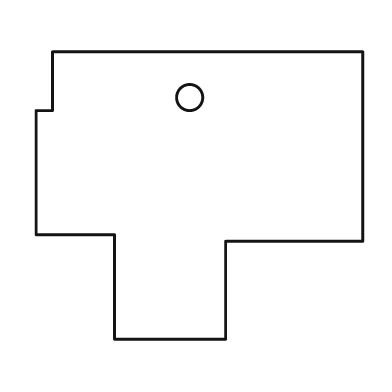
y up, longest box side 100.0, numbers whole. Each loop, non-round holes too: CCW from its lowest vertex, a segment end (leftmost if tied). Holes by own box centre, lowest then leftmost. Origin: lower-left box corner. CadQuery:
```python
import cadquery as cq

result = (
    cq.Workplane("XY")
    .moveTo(24.0, 0.0)
    .lineTo(58.0, 0.0)
    .lineTo(58.0, 30.0)
    .lineTo(100.0, 30.0)
    .lineTo(100.0, 88.0)
    .lineTo(5.0, 88.0)
    .lineTo(5.0, 70.0)
    .lineTo(0.0, 70.0)
    .lineTo(0.0, 32.0)
    .lineTo(24.0, 32.0)
    .close()
    .moveTo(47.0, 74.0)
    .circle(4.0)
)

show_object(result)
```